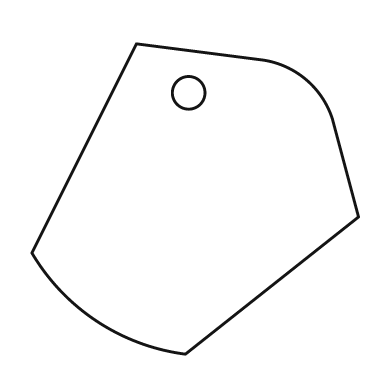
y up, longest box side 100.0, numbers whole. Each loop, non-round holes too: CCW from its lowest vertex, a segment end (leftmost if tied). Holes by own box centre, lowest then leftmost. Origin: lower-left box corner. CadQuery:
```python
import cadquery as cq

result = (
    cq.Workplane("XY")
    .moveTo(47.0, 0.0)
    .lineTo(100.0, 42.0)
    .lineTo(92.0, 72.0)
    .threePointArc((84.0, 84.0), (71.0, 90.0))
    .lineTo(32.0, 95.0)
    .lineTo(0.0, 31.0)
    .threePointArc((20.0, 10.0), (47.0, 0.0))
    .close()
    .moveTo(48.0, 80.0)
    .circle(5.0)
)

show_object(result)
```